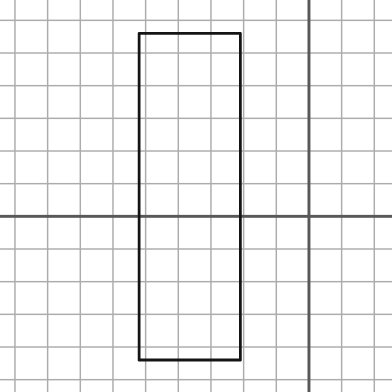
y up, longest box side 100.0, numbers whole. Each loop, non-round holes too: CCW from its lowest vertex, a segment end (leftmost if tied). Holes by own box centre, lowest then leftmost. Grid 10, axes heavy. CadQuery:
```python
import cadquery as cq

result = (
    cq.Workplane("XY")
    .moveTo(-52.0, -44.0)
    .lineTo(-21.0, -44.0)
    .lineTo(-21.0, 56.0)
    .lineTo(-52.0, 56.0)
    .close()
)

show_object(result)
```